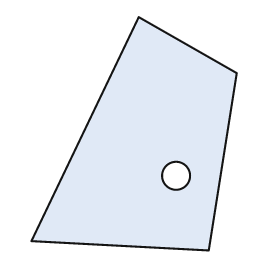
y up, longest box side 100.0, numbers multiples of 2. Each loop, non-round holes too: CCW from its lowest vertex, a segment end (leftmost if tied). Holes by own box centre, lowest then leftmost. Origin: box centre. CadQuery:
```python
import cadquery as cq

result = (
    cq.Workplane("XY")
    .moveTo(32.0, -50.0)
    .lineTo(44.0, 26.0)
    .lineTo(2.0, 50.0)
    .lineTo(-44.0, -46.0)
    .close()
    .moveTo(18.0, -18.0)
    .circle(6.0)
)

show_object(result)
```